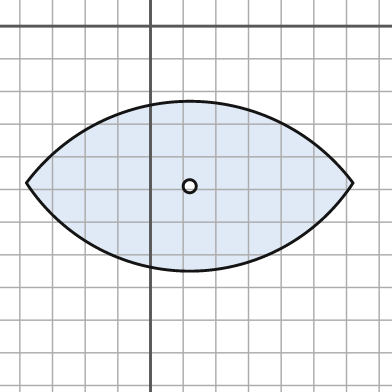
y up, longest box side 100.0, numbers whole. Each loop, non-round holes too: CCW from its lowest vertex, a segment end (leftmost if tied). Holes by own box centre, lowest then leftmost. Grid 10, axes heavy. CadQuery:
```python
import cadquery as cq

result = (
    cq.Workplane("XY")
    .moveTo(-38.0, -48.0)
    .threePointArc((12.0, -75.0), (62.0, -48.0))
    .threePointArc((12.0, -23.0), (-38.0, -48.0))
    .close()
    .moveTo(12.0, -49.0)
    .circle(2.0)
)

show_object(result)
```